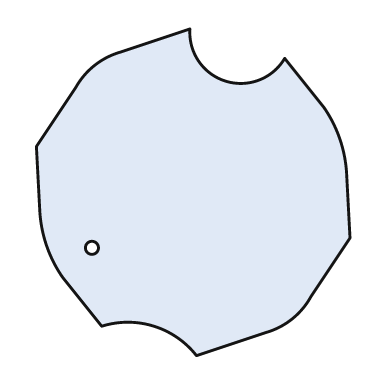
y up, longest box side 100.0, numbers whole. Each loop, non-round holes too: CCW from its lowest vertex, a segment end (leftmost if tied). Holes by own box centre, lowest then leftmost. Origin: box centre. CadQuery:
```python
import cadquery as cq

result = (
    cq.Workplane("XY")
    .moveTo(1.0, -50.0)
    .lineTo(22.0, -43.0)
    .threePointArc((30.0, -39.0), (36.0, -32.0))
    .lineTo(48.0, -14.0)
    .lineTo(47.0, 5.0)
    .threePointArc((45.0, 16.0), (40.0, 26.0))
    .lineTo(28.0, 41.0)
    .threePointArc((10.0, 34.0), (-1.0, 50.0))
    .lineTo(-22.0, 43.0)
    .threePointArc((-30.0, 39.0), (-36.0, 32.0))
    .lineTo(-48.0, 14.0)
    .lineTo(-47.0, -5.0)
    .threePointArc((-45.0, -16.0), (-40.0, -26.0))
    .lineTo(-28.0, -41.0)
    .threePointArc((-12.0, -41.0), (1.0, -50.0))
    .close()
    .moveTo(-31.0, -17.0)
    .circle(2.0)
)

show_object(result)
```